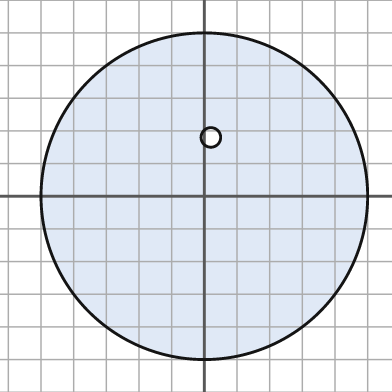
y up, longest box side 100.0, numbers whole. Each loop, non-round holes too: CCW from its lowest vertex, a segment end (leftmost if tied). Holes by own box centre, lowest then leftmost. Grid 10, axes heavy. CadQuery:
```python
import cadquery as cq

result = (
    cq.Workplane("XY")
    .moveTo(0.0, 0.0)
    .circle(50.0)
    .moveTo(2.0, 18.0)
    .circle(3.0)
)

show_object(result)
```